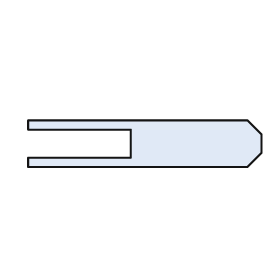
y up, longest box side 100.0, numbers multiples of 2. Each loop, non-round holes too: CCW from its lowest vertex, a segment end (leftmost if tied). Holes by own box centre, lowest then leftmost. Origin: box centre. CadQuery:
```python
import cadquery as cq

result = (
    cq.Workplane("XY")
    .moveTo(-50.0, -10.0)
    .lineTo(44.0, -10.0)
    .lineTo(50.0, -4.0)
    .lineTo(50.0, 4.0)
    .lineTo(44.0, 10.0)
    .lineTo(-50.0, 10.0)
    .lineTo(-50.0, 6.0)
    .lineTo(-6.0, 6.0)
    .lineTo(-6.0, -6.0)
    .lineTo(-50.0, -6.0)
    .close()
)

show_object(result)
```